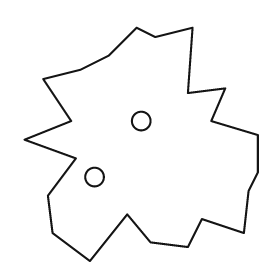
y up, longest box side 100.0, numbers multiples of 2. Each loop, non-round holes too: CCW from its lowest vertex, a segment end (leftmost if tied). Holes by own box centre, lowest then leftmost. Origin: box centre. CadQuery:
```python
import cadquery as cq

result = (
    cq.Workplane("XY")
    .moveTo(-22.0, -50.0)
    .lineTo(-6.0, -30.0)
    .lineTo(4.0, -42.0)
    .lineTo(20.0, -44.0)
    .lineTo(26.0, -32.0)
    .lineTo(44.0, -38.0)
    .lineTo(46.0, -20.0)
    .lineTo(50.0, -12.0)
    .lineTo(50.0, 4.0)
    .lineTo(30.0, 10.0)
    .lineTo(36.0, 24.0)
    .lineTo(20.0, 22.0)
    .lineTo(22.0, 50.0)
    .lineTo(6.0, 46.0)
    .lineTo(-2.0, 50.0)
    .lineTo(-14.0, 38.0)
    .lineTo(-26.0, 32.0)
    .lineTo(-42.0, 28.0)
    .lineTo(-30.0, 10.0)
    .lineTo(-50.0, 2.0)
    .lineTo(-28.0, -6.0)
    .lineTo(-40.0, -22.0)
    .lineTo(-38.0, -38.0)
    .close()
    .moveTo(-20.0, -14.0)
    .circle(4.0)
    .moveTo(0.0, 10.0)
    .circle(4.0)
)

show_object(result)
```